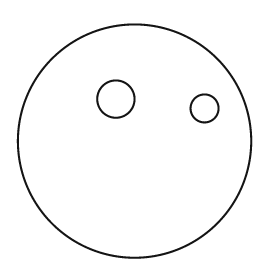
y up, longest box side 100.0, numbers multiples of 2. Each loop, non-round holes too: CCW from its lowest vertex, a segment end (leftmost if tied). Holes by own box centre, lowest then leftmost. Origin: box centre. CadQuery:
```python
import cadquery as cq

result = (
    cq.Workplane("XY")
    .moveTo(0.0, 0.0)
    .circle(50.0)
    .moveTo(30.0, 14.0)
    .circle(6.0)
    .moveTo(-8.0, 18.0)
    .circle(8.0)
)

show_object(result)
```